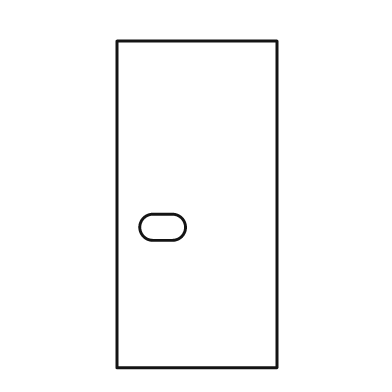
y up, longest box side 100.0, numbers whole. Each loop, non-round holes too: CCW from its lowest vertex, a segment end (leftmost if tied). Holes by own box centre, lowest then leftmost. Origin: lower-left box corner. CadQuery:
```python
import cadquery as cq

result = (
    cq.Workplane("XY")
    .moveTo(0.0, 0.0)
    .lineTo(49.0, 0.0)
    .lineTo(49.0, 100.0)
    .lineTo(0.0, 100.0)
    .close()
    .moveTo(11.0, 39.0)
    .lineTo(17.0, 39.0)
    .threePointArc((21.0, 43.0), (17.0, 47.0))
    .lineTo(11.0, 47.0)
    .threePointArc((7.0, 43.0), (11.0, 39.0))
    .close()
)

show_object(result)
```